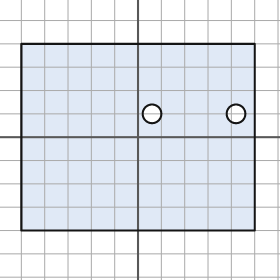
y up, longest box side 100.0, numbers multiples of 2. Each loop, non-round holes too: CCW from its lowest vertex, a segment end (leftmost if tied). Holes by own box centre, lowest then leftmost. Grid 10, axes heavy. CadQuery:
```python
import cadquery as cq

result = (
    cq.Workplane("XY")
    .moveTo(-50.0, -40.0)
    .lineTo(50.0, -40.0)
    .lineTo(50.0, 40.0)
    .lineTo(-50.0, 40.0)
    .close()
    .moveTo(6.0, 10.0)
    .circle(4.0)
    .moveTo(42.0, 10.0)
    .circle(4.0)
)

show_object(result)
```